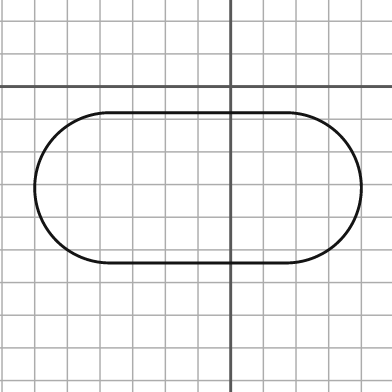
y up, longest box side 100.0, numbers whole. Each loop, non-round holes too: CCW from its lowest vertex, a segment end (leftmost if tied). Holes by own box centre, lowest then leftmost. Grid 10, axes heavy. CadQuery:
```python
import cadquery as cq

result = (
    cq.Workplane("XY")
    .moveTo(-37.0, -54.0)
    .lineTo(17.0, -54.0)
    .threePointArc((40.0, -31.0), (17.0, -8.0))
    .lineTo(-37.0, -8.0)
    .threePointArc((-60.0, -31.0), (-37.0, -54.0))
    .close()
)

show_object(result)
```